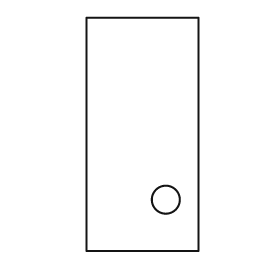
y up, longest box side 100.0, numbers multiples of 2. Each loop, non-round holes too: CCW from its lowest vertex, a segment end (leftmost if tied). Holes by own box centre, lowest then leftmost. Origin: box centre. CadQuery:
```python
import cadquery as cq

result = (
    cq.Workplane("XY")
    .moveTo(-24.0, -50.0)
    .lineTo(24.0, -50.0)
    .lineTo(24.0, 50.0)
    .lineTo(-24.0, 50.0)
    .close()
    .moveTo(10.0, -28.0)
    .circle(6.0)
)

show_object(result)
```